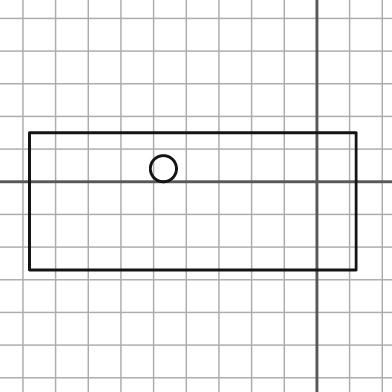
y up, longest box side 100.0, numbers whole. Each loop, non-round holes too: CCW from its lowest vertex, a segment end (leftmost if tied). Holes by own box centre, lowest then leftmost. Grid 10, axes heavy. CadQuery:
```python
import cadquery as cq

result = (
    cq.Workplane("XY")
    .moveTo(-88.0, -27.0)
    .lineTo(12.0, -27.0)
    .lineTo(12.0, 15.0)
    .lineTo(-88.0, 15.0)
    .close()
    .moveTo(-47.0, 4.0)
    .circle(4.0)
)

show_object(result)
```